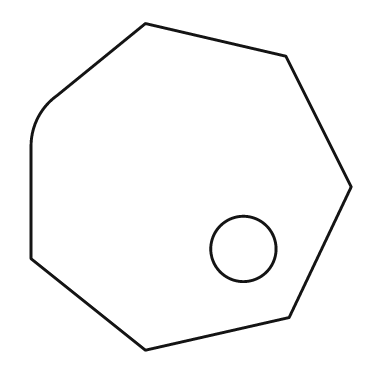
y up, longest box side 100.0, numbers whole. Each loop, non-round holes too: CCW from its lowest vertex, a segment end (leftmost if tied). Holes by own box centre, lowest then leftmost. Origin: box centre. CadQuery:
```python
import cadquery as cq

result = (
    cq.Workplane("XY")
    .moveTo(-14.0, -50.0)
    .lineTo(30.0, -40.0)
    .lineTo(49.0, 0.0)
    .lineTo(29.0, 40.0)
    .lineTo(-14.0, 50.0)
    .lineTo(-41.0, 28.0)
    .threePointArc((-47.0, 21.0), (-49.0, 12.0))
    .lineTo(-49.0, -22.0)
    .close()
    .moveTo(16.0, -19.0)
    .circle(10.0)
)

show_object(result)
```